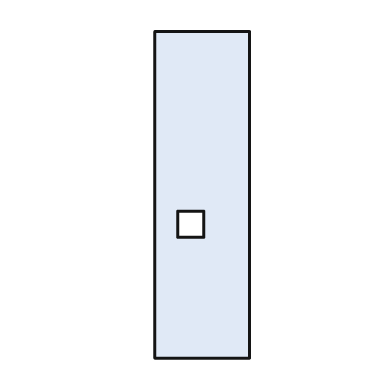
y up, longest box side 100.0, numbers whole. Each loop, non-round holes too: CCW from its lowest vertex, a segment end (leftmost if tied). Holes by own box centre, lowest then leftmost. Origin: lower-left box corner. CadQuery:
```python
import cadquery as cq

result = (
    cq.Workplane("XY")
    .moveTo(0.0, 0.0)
    .lineTo(29.0, 0.0)
    .lineTo(29.0, 100.0)
    .lineTo(0.0, 100.0)
    .close()
    .moveTo(7.0, 37.0)
    .lineTo(15.0, 37.0)
    .lineTo(15.0, 45.0)
    .lineTo(7.0, 45.0)
    .close()
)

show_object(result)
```